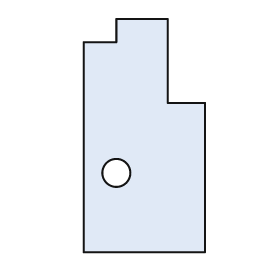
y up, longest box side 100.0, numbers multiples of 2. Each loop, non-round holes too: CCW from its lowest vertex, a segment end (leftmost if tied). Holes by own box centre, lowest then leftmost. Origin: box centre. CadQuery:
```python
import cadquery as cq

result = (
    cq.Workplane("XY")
    .moveTo(-26.0, -50.0)
    .lineTo(26.0, -50.0)
    .lineTo(26.0, 14.0)
    .lineTo(10.0, 14.0)
    .lineTo(10.0, 50.0)
    .lineTo(-12.0, 50.0)
    .lineTo(-12.0, 40.0)
    .lineTo(-26.0, 40.0)
    .close()
    .moveTo(-12.0, -16.0)
    .circle(6.0)
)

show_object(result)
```